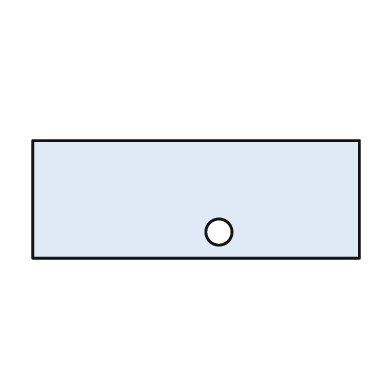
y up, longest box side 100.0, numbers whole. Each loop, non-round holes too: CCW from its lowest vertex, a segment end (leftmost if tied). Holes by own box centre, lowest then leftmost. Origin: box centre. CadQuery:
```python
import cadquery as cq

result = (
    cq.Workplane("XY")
    .moveTo(-50.0, -18.0)
    .lineTo(50.0, -18.0)
    .lineTo(50.0, 18.0)
    .lineTo(-50.0, 18.0)
    .close()
    .moveTo(7.0, -10.0)
    .circle(4.0)
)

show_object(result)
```